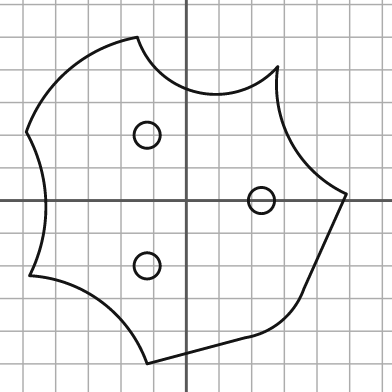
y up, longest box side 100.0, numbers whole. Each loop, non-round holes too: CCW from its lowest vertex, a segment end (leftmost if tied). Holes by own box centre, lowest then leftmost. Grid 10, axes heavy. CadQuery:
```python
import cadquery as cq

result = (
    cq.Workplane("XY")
    .moveTo(-12.0, -50.0)
    .lineTo(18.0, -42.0)
    .threePointArc((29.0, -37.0), (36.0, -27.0))
    .lineTo(49.0, 2.0)
    .threePointArc((32.0, 18.0), (28.0, 41.0))
    .threePointArc((4.0, 33.0), (-15.0, 50.0))
    .threePointArc((-36.0, 40.0), (-49.0, 21.0))
    .threePointArc((-43.0, -1.0), (-48.0, -23.0))
    .threePointArc((-26.0, -31.0), (-12.0, -50.0))
    .close()
    .moveTo(-12.0, -20.0)
    .circle(4.0)
    .moveTo(23.0, 0.0)
    .circle(4.0)
    .moveTo(-12.0, 20.0)
    .circle(4.0)
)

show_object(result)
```